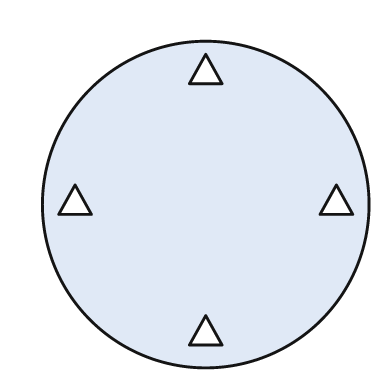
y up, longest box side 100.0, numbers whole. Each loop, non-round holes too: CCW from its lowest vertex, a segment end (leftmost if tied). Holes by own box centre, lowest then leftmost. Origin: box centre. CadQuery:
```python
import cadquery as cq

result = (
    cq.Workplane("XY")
    .moveTo(0.0, 0.0)
    .circle(50.0)
    .moveTo(-5.0, -43.0)
    .lineTo(5.0, -43.0)
    .lineTo(0.0, -34.0)
    .close()
    .moveTo(-45.0, -3.0)
    .lineTo(-35.0, -3.0)
    .lineTo(-40.0, 6.0)
    .close()
    .moveTo(35.0, -3.0)
    .lineTo(45.0, -3.0)
    .lineTo(40.0, 6.0)
    .close()
    .moveTo(-5.0, 37.0)
    .lineTo(5.0, 37.0)
    .lineTo(0.0, 46.0)
    .close()
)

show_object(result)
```